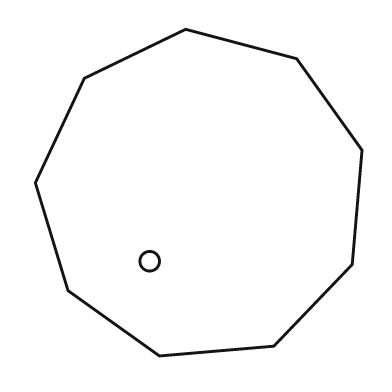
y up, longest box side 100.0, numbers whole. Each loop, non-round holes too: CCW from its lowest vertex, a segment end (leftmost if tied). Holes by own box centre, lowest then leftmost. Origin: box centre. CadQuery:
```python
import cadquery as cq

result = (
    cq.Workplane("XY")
    .moveTo(-12.0, -50.0)
    .lineTo(23.0, -47.0)
    .lineTo(47.0, -22.0)
    .lineTo(50.0, 13.0)
    .lineTo(30.0, 41.0)
    .lineTo(-4.0, 50.0)
    .lineTo(-35.0, 35.0)
    .lineTo(-50.0, 3.0)
    .lineTo(-40.0, -30.0)
    .close()
    .moveTo(-15.0, -21.0)
    .circle(3.0)
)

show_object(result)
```